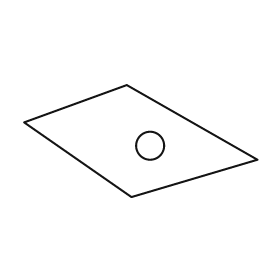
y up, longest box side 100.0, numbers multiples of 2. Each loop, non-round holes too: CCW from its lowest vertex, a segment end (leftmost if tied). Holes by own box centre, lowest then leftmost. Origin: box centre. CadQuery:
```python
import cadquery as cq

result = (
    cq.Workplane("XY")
    .moveTo(-4.0, -24.0)
    .lineTo(50.0, -8.0)
    .lineTo(-6.0, 24.0)
    .lineTo(-50.0, 8.0)
    .close()
    .moveTo(4.0, -2.0)
    .circle(6.0)
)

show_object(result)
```